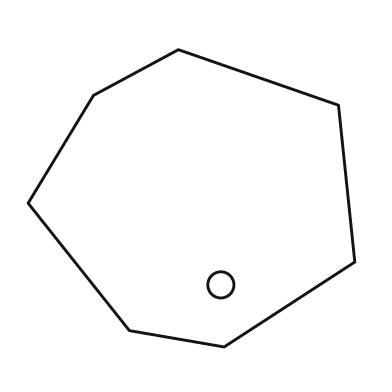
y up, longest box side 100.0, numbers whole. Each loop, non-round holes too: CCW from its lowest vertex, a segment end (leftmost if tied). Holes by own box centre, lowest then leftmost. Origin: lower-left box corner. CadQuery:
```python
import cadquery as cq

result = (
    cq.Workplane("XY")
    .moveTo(60.0, 0.0)
    .lineTo(100.0, 26.0)
    .lineTo(95.0, 74.0)
    .lineTo(46.0, 91.0)
    .lineTo(20.0, 77.0)
    .lineTo(0.0, 44.0)
    .lineTo(31.0, 5.0)
    .close()
    .moveTo(59.0, 19.0)
    .circle(4.0)
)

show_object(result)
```